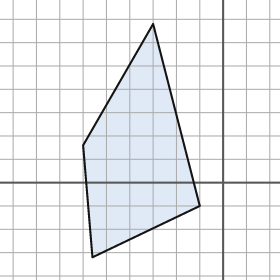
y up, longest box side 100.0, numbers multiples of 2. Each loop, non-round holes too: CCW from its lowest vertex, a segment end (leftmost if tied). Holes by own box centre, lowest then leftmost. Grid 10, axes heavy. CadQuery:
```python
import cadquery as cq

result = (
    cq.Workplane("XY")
    .moveTo(-56.0, -32.0)
    .lineTo(-10.0, -10.0)
    .lineTo(-30.0, 68.0)
    .lineTo(-60.0, 16.0)
    .close()
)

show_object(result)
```